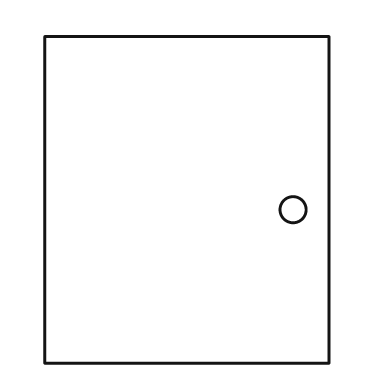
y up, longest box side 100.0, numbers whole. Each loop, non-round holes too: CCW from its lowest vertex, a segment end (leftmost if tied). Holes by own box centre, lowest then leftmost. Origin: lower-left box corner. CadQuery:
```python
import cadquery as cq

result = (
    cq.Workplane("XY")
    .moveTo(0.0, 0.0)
    .lineTo(87.0, 0.0)
    .lineTo(87.0, 100.0)
    .lineTo(0.0, 100.0)
    .close()
    .moveTo(76.0, 47.0)
    .circle(4.0)
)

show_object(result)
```